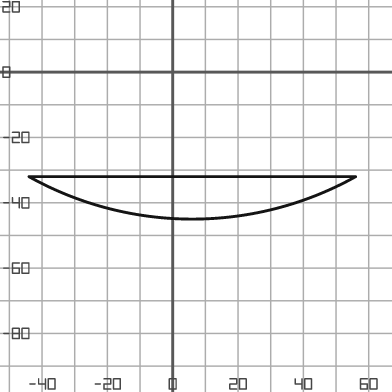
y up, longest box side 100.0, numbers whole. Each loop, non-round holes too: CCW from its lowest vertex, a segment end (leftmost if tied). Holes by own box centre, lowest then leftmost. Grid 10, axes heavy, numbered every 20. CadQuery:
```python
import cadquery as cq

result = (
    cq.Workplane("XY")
    .moveTo(-44.0, -32.0)
    .threePointArc((6.0, -45.0), (56.0, -32.0))
    .close()
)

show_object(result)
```